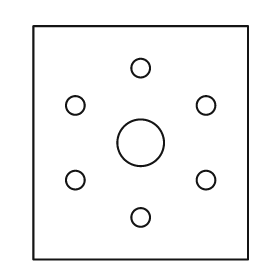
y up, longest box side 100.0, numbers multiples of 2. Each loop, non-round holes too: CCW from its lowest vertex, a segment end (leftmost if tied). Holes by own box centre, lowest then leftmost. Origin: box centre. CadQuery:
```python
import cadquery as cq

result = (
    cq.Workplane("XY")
    .moveTo(-46.0, -50.0)
    .lineTo(46.0, -50.0)
    .lineTo(46.0, 50.0)
    .lineTo(-46.0, 50.0)
    .close()
    .moveTo(0.0, -32.0)
    .circle(4.0)
    .moveTo(-28.0, -16.0)
    .circle(4.0)
    .moveTo(28.0, -16.0)
    .circle(4.0)
    .moveTo(0.0, 0.0)
    .circle(10.0)
    .moveTo(-28.0, 16.0)
    .circle(4.0)
    .moveTo(28.0, 16.0)
    .circle(4.0)
    .moveTo(0.0, 32.0)
    .circle(4.0)
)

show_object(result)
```